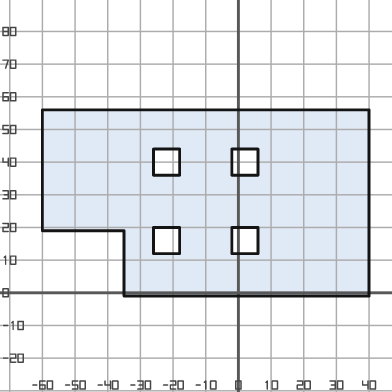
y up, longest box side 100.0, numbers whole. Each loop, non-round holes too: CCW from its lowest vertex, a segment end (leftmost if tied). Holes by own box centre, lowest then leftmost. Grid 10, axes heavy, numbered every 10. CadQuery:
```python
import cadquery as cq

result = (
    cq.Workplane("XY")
    .moveTo(-35.0, -1.0)
    .lineTo(40.0, -1.0)
    .lineTo(40.0, 56.0)
    .lineTo(-60.0, 56.0)
    .lineTo(-60.0, 19.0)
    .lineTo(-35.0, 19.0)
    .close()
    .moveTo(-26.0, 12.0)
    .lineTo(-18.0, 12.0)
    .lineTo(-18.0, 20.0)
    .lineTo(-26.0, 20.0)
    .close()
    .moveTo(-2.0, 12.0)
    .lineTo(6.0, 12.0)
    .lineTo(6.0, 20.0)
    .lineTo(-2.0, 20.0)
    .close()
    .moveTo(-26.0, 36.0)
    .lineTo(-18.0, 36.0)
    .lineTo(-18.0, 44.0)
    .lineTo(-26.0, 44.0)
    .close()
    .moveTo(-2.0, 36.0)
    .lineTo(6.0, 36.0)
    .lineTo(6.0, 44.0)
    .lineTo(-2.0, 44.0)
    .close()
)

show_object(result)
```